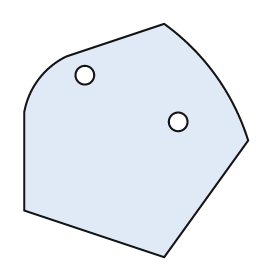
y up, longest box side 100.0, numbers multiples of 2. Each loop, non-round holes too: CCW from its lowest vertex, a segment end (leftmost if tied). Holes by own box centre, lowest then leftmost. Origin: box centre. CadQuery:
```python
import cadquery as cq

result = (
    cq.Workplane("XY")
    .moveTo(12.0, -50.0)
    .lineTo(48.0, 0.0)
    .threePointArc((34.0, 28.0), (12.0, 50.0))
    .lineTo(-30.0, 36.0)
    .threePointArc((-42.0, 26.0), (-48.0, 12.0))
    .lineTo(-48.0, -30.0)
    .close()
    .moveTo(18.0, 8.0)
    .circle(4.0)
    .moveTo(-22.0, 28.0)
    .circle(4.0)
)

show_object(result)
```